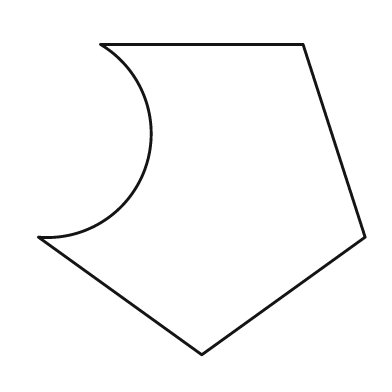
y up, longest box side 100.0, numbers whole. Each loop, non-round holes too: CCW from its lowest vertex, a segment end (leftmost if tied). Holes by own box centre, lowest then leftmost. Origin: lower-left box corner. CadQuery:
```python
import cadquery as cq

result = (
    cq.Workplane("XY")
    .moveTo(50.0, 0.0)
    .lineTo(100.0, 36.0)
    .lineTo(81.0, 95.0)
    .lineTo(19.0, 95.0)
    .threePointArc((33.0, 58.0), (0.0, 36.0))
    .close()
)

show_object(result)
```